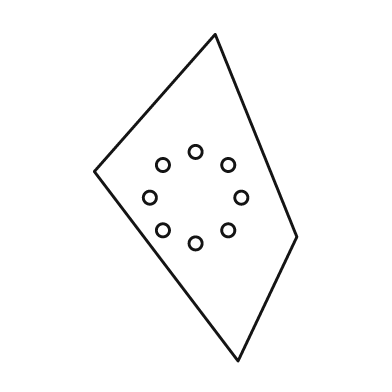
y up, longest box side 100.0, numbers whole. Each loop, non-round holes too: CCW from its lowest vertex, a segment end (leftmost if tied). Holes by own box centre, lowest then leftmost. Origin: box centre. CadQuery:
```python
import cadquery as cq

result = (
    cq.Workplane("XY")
    .moveTo(13.0, -50.0)
    .lineTo(31.0, -12.0)
    .lineTo(6.0, 50.0)
    .lineTo(-31.0, 8.0)
    .close()
    .moveTo(0.0, -14.0)
    .circle(2.0)
    .moveTo(-10.0, -10.0)
    .circle(2.0)
    .moveTo(10.0, -10.0)
    .circle(2.0)
    .moveTo(-14.0, 0.0)
    .circle(2.0)
    .moveTo(14.0, 0.0)
    .circle(2.0)
    .moveTo(-10.0, 10.0)
    .circle(2.0)
    .moveTo(10.0, 10.0)
    .circle(2.0)
    .moveTo(0.0, 14.0)
    .circle(2.0)
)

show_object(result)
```